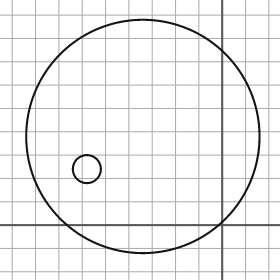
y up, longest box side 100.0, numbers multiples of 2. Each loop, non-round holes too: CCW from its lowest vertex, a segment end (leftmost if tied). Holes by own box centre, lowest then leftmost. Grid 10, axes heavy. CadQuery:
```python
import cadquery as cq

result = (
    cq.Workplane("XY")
    .moveTo(-34.0, 38.0)
    .circle(50.0)
    .moveTo(-58.0, 24.0)
    .circle(6.0)
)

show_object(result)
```